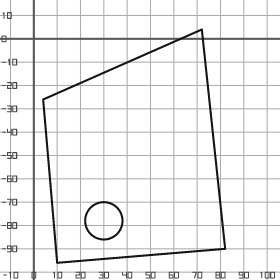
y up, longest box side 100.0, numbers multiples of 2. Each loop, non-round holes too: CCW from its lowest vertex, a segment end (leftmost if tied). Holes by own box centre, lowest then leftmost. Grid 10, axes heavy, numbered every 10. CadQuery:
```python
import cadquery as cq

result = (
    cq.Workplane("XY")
    .moveTo(10.0, -96.0)
    .lineTo(82.0, -90.0)
    .lineTo(72.0, 4.0)
    .lineTo(4.0, -26.0)
    .close()
    .moveTo(30.0, -78.0)
    .circle(8.0)
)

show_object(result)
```